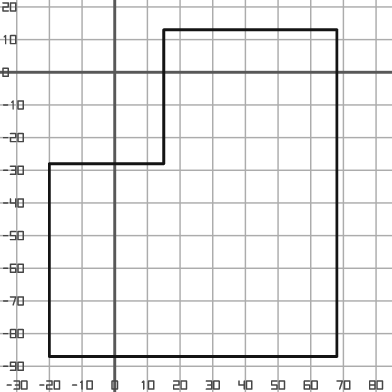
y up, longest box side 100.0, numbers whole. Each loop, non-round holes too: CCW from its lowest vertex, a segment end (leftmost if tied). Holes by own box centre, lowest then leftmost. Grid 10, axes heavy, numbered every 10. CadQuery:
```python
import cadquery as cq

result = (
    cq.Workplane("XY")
    .moveTo(-20.0, -87.0)
    .lineTo(68.0, -87.0)
    .lineTo(68.0, 13.0)
    .lineTo(15.0, 13.0)
    .lineTo(15.0, -28.0)
    .lineTo(-20.0, -28.0)
    .close()
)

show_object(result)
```